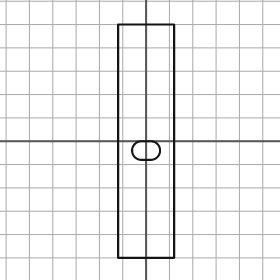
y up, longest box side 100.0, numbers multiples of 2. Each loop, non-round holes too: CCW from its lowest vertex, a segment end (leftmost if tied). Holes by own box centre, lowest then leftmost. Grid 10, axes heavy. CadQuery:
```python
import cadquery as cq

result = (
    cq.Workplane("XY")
    .moveTo(-12.0, -50.0)
    .lineTo(12.0, -50.0)
    .lineTo(12.0, 50.0)
    .lineTo(-12.0, 50.0)
    .close()
    .moveTo(-2.0, -8.0)
    .lineTo(2.0, -8.0)
    .threePointArc((6.0, -4.0), (2.0, 0.0))
    .lineTo(-2.0, 0.0)
    .threePointArc((-6.0, -4.0), (-2.0, -8.0))
    .close()
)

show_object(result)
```